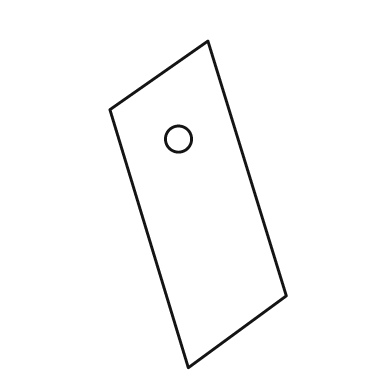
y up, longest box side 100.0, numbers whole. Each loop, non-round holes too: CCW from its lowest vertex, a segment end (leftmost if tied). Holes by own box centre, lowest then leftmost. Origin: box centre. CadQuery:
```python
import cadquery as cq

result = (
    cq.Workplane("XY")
    .moveTo(-3.0, -50.0)
    .lineTo(27.0, -28.0)
    .lineTo(3.0, 50.0)
    .lineTo(-27.0, 29.0)
    .close()
    .moveTo(-6.0, 20.0)
    .circle(4.0)
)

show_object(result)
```